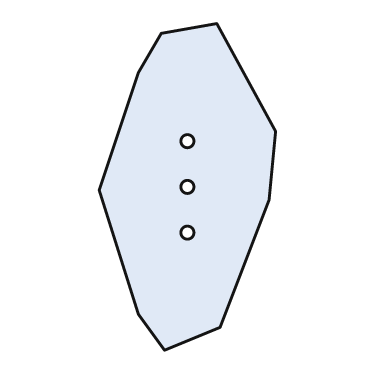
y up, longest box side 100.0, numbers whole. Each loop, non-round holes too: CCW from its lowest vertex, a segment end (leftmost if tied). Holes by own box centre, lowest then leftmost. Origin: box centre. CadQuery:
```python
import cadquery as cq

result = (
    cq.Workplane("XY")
    .moveTo(-7.0, -50.0)
    .lineTo(10.0, -43.0)
    .lineTo(25.0, -4.0)
    .lineTo(27.0, 17.0)
    .lineTo(9.0, 50.0)
    .lineTo(-8.0, 47.0)
    .lineTo(-15.0, 35.0)
    .lineTo(-27.0, -1.0)
    .lineTo(-15.0, -39.0)
    .close()
    .moveTo(0.0, -14.0)
    .circle(2.0)
    .moveTo(0.0, 0.0)
    .circle(2.0)
    .moveTo(0.0, 14.0)
    .circle(2.0)
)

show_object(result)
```